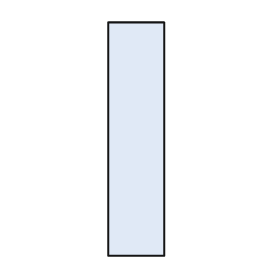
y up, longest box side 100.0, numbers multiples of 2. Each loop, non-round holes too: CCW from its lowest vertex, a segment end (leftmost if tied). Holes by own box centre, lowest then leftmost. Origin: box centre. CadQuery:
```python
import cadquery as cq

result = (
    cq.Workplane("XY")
    .moveTo(-12.0, -50.0)
    .lineTo(12.0, -50.0)
    .lineTo(12.0, 50.0)
    .lineTo(-12.0, 50.0)
    .close()
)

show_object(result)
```